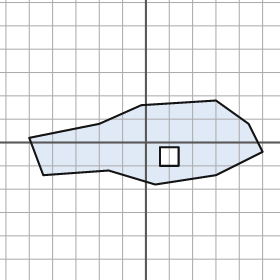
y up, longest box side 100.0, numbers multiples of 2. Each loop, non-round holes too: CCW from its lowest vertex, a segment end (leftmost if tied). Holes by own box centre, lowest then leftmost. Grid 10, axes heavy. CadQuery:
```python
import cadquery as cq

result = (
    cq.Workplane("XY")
    .moveTo(4.0, -18.0)
    .lineTo(30.0, -14.0)
    .lineTo(50.0, -4.0)
    .lineTo(44.0, 8.0)
    .lineTo(30.0, 18.0)
    .lineTo(-2.0, 16.0)
    .lineTo(-20.0, 8.0)
    .lineTo(-50.0, 2.0)
    .lineTo(-44.0, -14.0)
    .lineTo(-16.0, -12.0)
    .close()
    .moveTo(6.0, -10.0)
    .lineTo(14.0, -10.0)
    .lineTo(14.0, -2.0)
    .lineTo(6.0, -2.0)
    .close()
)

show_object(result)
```